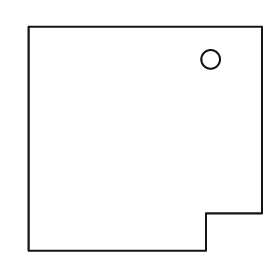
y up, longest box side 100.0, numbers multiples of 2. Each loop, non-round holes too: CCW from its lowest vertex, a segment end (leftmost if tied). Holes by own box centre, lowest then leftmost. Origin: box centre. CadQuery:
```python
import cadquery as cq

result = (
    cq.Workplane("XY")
    .moveTo(-50.0, -48.0)
    .lineTo(26.0, -48.0)
    .lineTo(26.0, -32.0)
    .lineTo(50.0, -32.0)
    .lineTo(50.0, 48.0)
    .lineTo(-50.0, 48.0)
    .close()
    .moveTo(28.0, 34.0)
    .circle(4.0)
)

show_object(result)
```